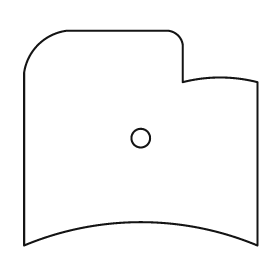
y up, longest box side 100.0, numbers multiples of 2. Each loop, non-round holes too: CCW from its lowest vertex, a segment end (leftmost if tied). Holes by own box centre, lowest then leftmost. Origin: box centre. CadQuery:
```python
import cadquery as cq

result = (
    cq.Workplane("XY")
    .moveTo(-50.0, -46.0)
    .threePointArc((0.0, -36.0), (50.0, -46.0))
    .lineTo(50.0, 24.0)
    .threePointArc((34.0, 26.0), (18.0, 24.0))
    .lineTo(18.0, 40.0)
    .threePointArc((16.0, 44.0), (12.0, 46.0))
    .lineTo(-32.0, 46.0)
    .threePointArc((-44.0, 40.0), (-50.0, 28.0))
    .close()
    .moveTo(0.0, 0.0)
    .circle(4.0)
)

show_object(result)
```